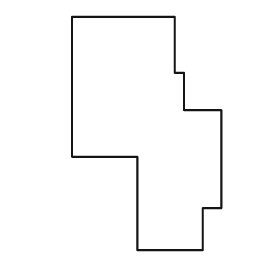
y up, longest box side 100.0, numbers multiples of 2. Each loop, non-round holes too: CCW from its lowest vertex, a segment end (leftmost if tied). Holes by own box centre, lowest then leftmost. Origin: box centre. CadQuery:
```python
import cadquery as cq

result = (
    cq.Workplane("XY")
    .moveTo(-4.0, -50.0)
    .lineTo(24.0, -50.0)
    .lineTo(24.0, -32.0)
    .lineTo(32.0, -32.0)
    .lineTo(32.0, 10.0)
    .lineTo(16.0, 10.0)
    .lineTo(16.0, 26.0)
    .lineTo(12.0, 26.0)
    .lineTo(12.0, 50.0)
    .lineTo(-32.0, 50.0)
    .lineTo(-32.0, -10.0)
    .lineTo(-4.0, -10.0)
    .close()
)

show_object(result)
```